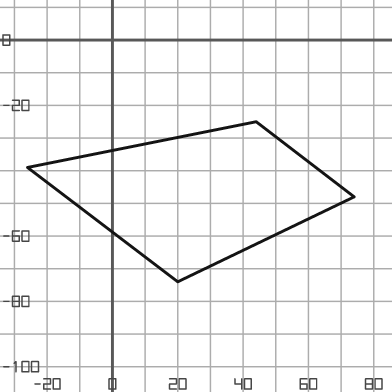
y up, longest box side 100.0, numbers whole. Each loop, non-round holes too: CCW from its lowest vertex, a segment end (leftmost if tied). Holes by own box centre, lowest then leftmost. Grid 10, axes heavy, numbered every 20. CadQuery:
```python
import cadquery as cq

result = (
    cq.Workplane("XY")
    .moveTo(20.0, -74.0)
    .lineTo(74.0, -48.0)
    .lineTo(44.0, -25.0)
    .lineTo(-26.0, -39.0)
    .close()
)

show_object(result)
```